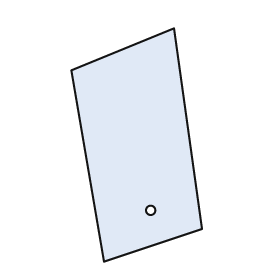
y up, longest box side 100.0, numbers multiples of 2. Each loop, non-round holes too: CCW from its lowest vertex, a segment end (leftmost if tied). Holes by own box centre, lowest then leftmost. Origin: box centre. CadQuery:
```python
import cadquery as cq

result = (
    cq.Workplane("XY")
    .moveTo(-14.0, -50.0)
    .lineTo(28.0, -36.0)
    .lineTo(16.0, 50.0)
    .lineTo(-28.0, 32.0)
    .close()
    .moveTo(6.0, -28.0)
    .circle(2.0)
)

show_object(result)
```